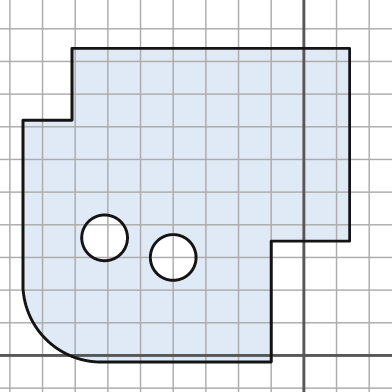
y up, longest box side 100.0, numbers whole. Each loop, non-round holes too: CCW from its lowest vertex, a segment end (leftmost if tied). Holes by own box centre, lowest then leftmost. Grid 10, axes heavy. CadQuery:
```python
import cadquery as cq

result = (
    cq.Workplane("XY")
    .moveTo(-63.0, -2.0)
    .lineTo(-10.0, -2.0)
    .lineTo(-10.0, 35.0)
    .lineTo(14.0, 35.0)
    .lineTo(14.0, 94.0)
    .lineTo(-71.0, 94.0)
    .lineTo(-71.0, 72.0)
    .lineTo(-86.0, 72.0)
    .lineTo(-86.0, 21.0)
    .threePointArc((-79.0, 5.0), (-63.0, -2.0))
    .close()
    .moveTo(-40.0, 30.0)
    .circle(7.0)
    .moveTo(-61.0, 36.0)
    .circle(7.0)
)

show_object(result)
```